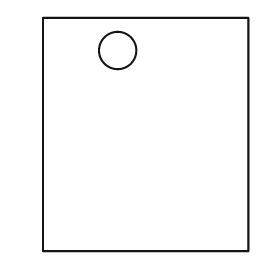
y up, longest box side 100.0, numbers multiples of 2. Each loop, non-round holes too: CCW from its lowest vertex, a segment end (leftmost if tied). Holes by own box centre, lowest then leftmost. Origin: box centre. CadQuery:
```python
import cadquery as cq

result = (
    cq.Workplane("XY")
    .moveTo(-44.0, -50.0)
    .lineTo(44.0, -50.0)
    .lineTo(44.0, 50.0)
    .lineTo(-44.0, 50.0)
    .close()
    .moveTo(-12.0, 36.0)
    .circle(8.0)
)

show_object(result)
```